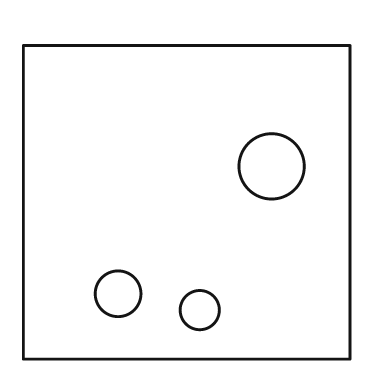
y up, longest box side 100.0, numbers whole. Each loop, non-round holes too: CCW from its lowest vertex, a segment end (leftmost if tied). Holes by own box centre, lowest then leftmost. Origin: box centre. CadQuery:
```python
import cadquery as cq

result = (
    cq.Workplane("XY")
    .moveTo(-50.0, -48.0)
    .lineTo(50.0, -48.0)
    .lineTo(50.0, 48.0)
    .lineTo(-50.0, 48.0)
    .close()
    .moveTo(4.0, -33.0)
    .circle(6.0)
    .moveTo(-21.0, -28.0)
    .circle(7.0)
    .moveTo(26.0, 11.0)
    .circle(10.0)
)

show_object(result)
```